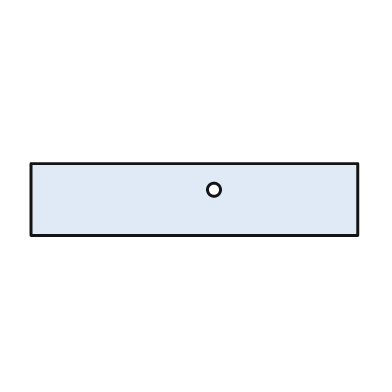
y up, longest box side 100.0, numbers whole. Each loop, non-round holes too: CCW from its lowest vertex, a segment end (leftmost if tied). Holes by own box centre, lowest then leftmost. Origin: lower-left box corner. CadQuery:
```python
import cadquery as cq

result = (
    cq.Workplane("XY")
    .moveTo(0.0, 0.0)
    .lineTo(100.0, 0.0)
    .lineTo(100.0, 22.0)
    .lineTo(0.0, 22.0)
    .close()
    .moveTo(56.0, 14.0)
    .circle(2.0)
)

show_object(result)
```